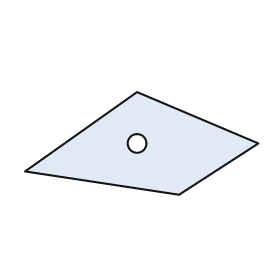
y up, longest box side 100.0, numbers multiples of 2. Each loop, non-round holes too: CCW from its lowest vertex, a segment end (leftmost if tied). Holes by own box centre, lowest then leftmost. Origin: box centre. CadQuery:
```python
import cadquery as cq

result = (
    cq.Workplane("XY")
    .moveTo(16.0, -22.0)
    .lineTo(50.0, 0.0)
    .lineTo(-2.0, 22.0)
    .lineTo(-50.0, -12.0)
    .close()
    .moveTo(-2.0, 0.0)
    .circle(4.0)
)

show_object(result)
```